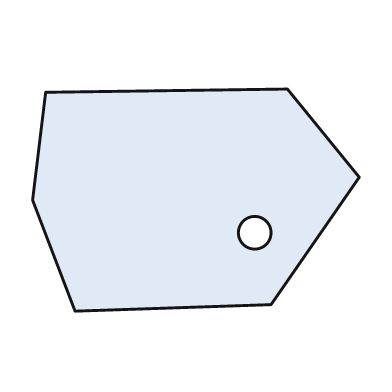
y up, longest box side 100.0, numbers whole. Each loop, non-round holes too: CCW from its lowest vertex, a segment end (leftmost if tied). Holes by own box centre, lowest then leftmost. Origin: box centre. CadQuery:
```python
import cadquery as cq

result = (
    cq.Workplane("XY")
    .moveTo(-37.0, -34.0)
    .lineTo(23.0, -32.0)
    .lineTo(50.0, 7.0)
    .lineTo(28.0, 34.0)
    .lineTo(-46.0, 33.0)
    .lineTo(-50.0, 0.0)
    .close()
    .moveTo(18.0, -10.0)
    .circle(5.0)
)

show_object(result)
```